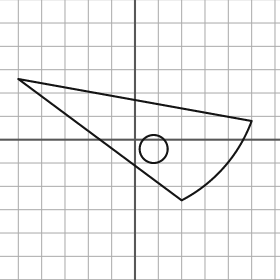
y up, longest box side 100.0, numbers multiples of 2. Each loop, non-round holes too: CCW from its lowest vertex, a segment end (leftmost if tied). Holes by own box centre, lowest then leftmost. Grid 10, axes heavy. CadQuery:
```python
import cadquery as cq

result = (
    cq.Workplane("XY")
    .moveTo(20.0, -26.0)
    .threePointArc((38.0, -12.0), (50.0, 8.0))
    .lineTo(-50.0, 26.0)
    .close()
    .moveTo(8.0, -4.0)
    .circle(6.0)
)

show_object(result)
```